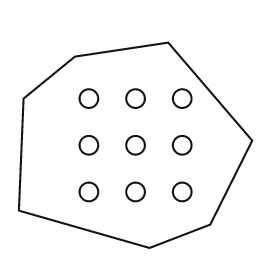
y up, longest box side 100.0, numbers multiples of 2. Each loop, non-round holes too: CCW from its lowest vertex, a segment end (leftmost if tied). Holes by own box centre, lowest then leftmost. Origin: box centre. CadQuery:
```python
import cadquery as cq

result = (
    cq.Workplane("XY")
    .moveTo(6.0, -44.0)
    .lineTo(32.0, -34.0)
    .lineTo(50.0, 2.0)
    .lineTo(14.0, 44.0)
    .lineTo(-26.0, 38.0)
    .lineTo(-48.0, 20.0)
    .lineTo(-50.0, -28.0)
    .close()
    .moveTo(-20.0, -20.0)
    .circle(4.0)
    .moveTo(0.0, -20.0)
    .circle(4.0)
    .moveTo(20.0, -20.0)
    .circle(4.0)
    .moveTo(-20.0, 0.0)
    .circle(4.0)
    .moveTo(0.0, 0.0)
    .circle(4.0)
    .moveTo(20.0, 0.0)
    .circle(4.0)
    .moveTo(-20.0, 20.0)
    .circle(4.0)
    .moveTo(0.0, 20.0)
    .circle(4.0)
    .moveTo(20.0, 20.0)
    .circle(4.0)
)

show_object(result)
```